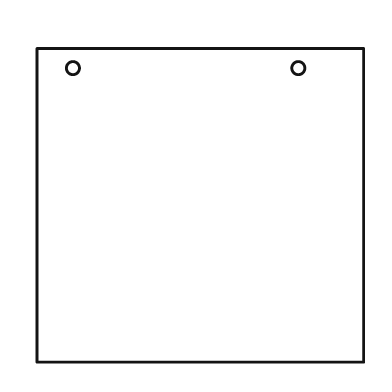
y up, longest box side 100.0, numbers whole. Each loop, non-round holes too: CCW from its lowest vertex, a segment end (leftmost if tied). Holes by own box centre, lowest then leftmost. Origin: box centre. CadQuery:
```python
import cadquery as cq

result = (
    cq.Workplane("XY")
    .moveTo(-50.0, -48.0)
    .lineTo(50.0, -48.0)
    .lineTo(50.0, 48.0)
    .lineTo(-50.0, 48.0)
    .close()
    .moveTo(-39.0, 42.0)
    .circle(2.0)
    .moveTo(30.0, 42.0)
    .circle(2.0)
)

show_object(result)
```